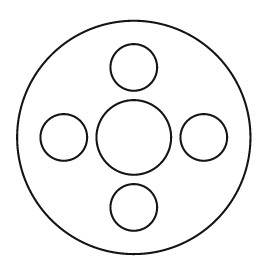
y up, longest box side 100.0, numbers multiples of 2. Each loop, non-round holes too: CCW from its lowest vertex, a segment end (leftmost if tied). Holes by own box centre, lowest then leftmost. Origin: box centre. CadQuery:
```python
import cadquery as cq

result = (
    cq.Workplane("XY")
    .moveTo(0.0, 0.0)
    .circle(50.0)
    .moveTo(0.0, -30.0)
    .circle(10.0)
    .moveTo(-30.0, 0.0)
    .circle(10.0)
    .moveTo(0.0, 0.0)
    .circle(16.0)
    .moveTo(30.0, 0.0)
    .circle(10.0)
    .moveTo(0.0, 30.0)
    .circle(10.0)
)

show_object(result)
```